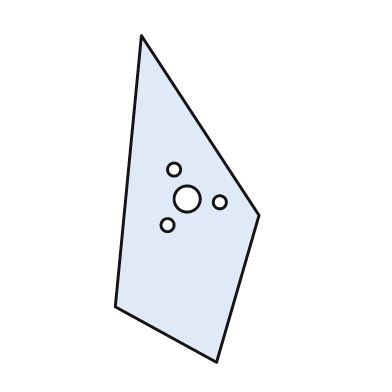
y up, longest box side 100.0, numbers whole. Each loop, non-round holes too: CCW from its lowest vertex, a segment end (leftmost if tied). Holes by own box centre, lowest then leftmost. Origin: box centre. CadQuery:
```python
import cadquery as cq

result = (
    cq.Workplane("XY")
    .moveTo(9.0, -50.0)
    .lineTo(22.0, -5.0)
    .lineTo(-14.0, 50.0)
    .lineTo(-22.0, -33.0)
    .close()
    .moveTo(-6.0, -8.0)
    .circle(2.0)
    .moveTo(10.0, -1.0)
    .circle(2.0)
    .moveTo(0.0, 0.0)
    .circle(4.0)
    .moveTo(-4.0, 9.0)
    .circle(2.0)
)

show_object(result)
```